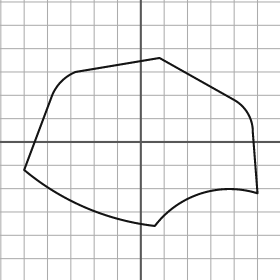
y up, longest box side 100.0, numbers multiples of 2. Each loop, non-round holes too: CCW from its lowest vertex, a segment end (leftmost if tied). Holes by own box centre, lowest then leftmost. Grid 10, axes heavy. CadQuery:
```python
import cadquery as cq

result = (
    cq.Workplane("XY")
    .moveTo(6.0, -36.0)
    .threePointArc((26.0, -22.0), (50.0, -22.0))
    .lineTo(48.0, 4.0)
    .threePointArc((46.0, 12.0), (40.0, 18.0))
    .lineTo(8.0, 36.0)
    .lineTo(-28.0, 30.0)
    .threePointArc((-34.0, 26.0), (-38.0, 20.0))
    .lineTo(-50.0, -12.0)
    .threePointArc((-24.0, -28.0), (6.0, -36.0))
    .close()
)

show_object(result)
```